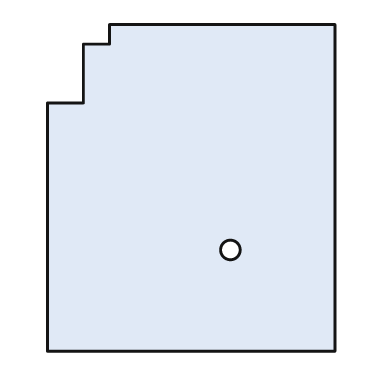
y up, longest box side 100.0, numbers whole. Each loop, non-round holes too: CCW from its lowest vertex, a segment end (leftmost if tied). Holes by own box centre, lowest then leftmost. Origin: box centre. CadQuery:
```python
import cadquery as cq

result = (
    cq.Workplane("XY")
    .moveTo(-44.0, -50.0)
    .lineTo(44.0, -50.0)
    .lineTo(44.0, 50.0)
    .lineTo(-25.0, 50.0)
    .lineTo(-25.0, 44.0)
    .lineTo(-33.0, 44.0)
    .lineTo(-33.0, 26.0)
    .lineTo(-44.0, 26.0)
    .close()
    .moveTo(12.0, -19.0)
    .circle(3.0)
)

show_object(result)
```